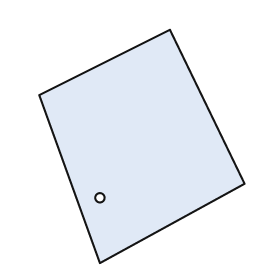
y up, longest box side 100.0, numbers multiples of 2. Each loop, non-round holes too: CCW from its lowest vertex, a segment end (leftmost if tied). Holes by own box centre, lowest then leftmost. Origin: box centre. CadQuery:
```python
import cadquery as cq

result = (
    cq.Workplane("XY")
    .moveTo(-18.0, -50.0)
    .lineTo(44.0, -16.0)
    .lineTo(12.0, 50.0)
    .lineTo(-44.0, 22.0)
    .close()
    .moveTo(-18.0, -22.0)
    .circle(2.0)
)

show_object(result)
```